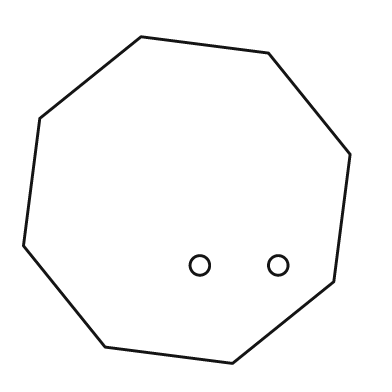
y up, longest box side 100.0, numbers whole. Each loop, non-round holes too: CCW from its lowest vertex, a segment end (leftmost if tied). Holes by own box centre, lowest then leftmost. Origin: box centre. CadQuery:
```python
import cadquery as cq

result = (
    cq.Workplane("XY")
    .moveTo(14.0, -50.0)
    .lineTo(45.0, -25.0)
    .lineTo(50.0, 14.0)
    .lineTo(25.0, 45.0)
    .lineTo(-14.0, 50.0)
    .lineTo(-45.0, 25.0)
    .lineTo(-50.0, -14.0)
    .lineTo(-25.0, -45.0)
    .close()
    .moveTo(4.0, -20.0)
    .circle(3.0)
    .moveTo(28.0, -20.0)
    .circle(3.0)
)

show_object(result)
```